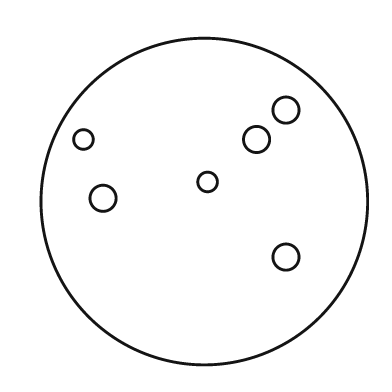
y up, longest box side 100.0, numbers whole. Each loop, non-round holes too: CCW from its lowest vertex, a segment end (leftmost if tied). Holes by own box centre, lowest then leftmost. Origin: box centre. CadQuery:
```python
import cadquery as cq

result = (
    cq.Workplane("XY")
    .moveTo(0.0, 0.0)
    .circle(50.0)
    .moveTo(25.0, -17.0)
    .circle(4.0)
    .moveTo(-31.0, 1.0)
    .circle(4.0)
    .moveTo(1.0, 6.0)
    .circle(3.0)
    .moveTo(-37.0, 19.0)
    .circle(3.0)
    .moveTo(16.0, 19.0)
    .circle(4.0)
    .moveTo(25.0, 28.0)
    .circle(4.0)
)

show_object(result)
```